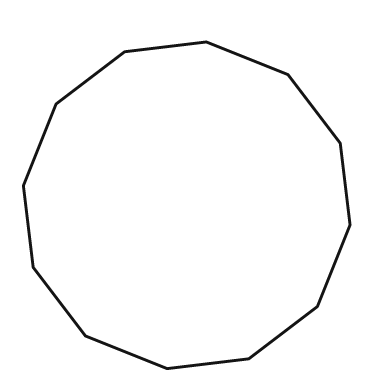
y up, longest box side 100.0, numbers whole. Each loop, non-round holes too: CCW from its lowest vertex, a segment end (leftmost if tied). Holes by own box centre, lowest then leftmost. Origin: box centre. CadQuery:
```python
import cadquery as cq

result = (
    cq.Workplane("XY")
    .moveTo(-6.0, -50.0)
    .lineTo(19.0, -47.0)
    .lineTo(40.0, -31.0)
    .lineTo(50.0, -6.0)
    .lineTo(47.0, 19.0)
    .lineTo(31.0, 40.0)
    .lineTo(6.0, 50.0)
    .lineTo(-19.0, 47.0)
    .lineTo(-40.0, 31.0)
    .lineTo(-50.0, 6.0)
    .lineTo(-47.0, -19.0)
    .lineTo(-31.0, -40.0)
    .close()
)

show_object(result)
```